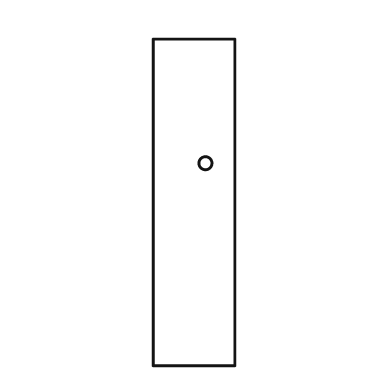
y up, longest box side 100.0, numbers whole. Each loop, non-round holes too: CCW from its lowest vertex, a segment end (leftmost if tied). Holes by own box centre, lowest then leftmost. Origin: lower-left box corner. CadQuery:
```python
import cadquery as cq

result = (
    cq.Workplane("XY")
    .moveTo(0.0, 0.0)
    .lineTo(25.0, 0.0)
    .lineTo(25.0, 100.0)
    .lineTo(0.0, 100.0)
    .close()
    .moveTo(16.0, 62.0)
    .circle(2.0)
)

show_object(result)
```